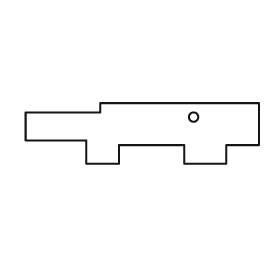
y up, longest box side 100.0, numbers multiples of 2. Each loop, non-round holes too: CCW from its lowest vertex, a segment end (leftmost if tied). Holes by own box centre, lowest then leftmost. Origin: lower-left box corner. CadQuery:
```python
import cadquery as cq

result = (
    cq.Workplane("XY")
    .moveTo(26.0, 0.0)
    .lineTo(40.0, 0.0)
    .lineTo(40.0, 8.0)
    .lineTo(68.0, 8.0)
    .lineTo(68.0, 0.0)
    .lineTo(86.0, 0.0)
    .lineTo(86.0, 8.0)
    .lineTo(100.0, 8.0)
    .lineTo(100.0, 26.0)
    .lineTo(32.0, 26.0)
    .lineTo(32.0, 22.0)
    .lineTo(0.0, 22.0)
    .lineTo(0.0, 10.0)
    .lineTo(26.0, 10.0)
    .close()
    .moveTo(72.0, 20.0)
    .circle(2.0)
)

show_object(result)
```